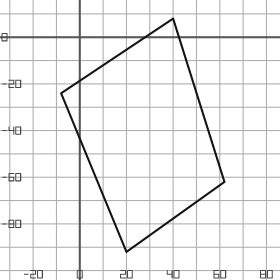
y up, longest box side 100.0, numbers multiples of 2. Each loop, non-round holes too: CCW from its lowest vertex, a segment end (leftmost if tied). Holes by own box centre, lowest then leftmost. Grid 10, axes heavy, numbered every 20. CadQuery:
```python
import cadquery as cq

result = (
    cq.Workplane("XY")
    .moveTo(20.0, -92.0)
    .lineTo(62.0, -62.0)
    .lineTo(40.0, 8.0)
    .lineTo(-8.0, -24.0)
    .close()
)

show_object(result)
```